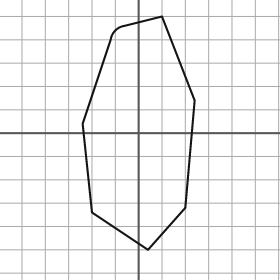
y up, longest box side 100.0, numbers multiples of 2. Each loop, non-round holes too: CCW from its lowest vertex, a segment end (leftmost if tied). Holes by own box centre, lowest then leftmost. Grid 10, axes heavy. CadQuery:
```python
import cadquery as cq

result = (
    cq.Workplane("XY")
    .moveTo(4.0, -50.0)
    .lineTo(20.0, -32.0)
    .lineTo(24.0, 14.0)
    .lineTo(10.0, 50.0)
    .lineTo(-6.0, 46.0)
    .threePointArc((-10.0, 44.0), (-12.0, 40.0))
    .lineTo(-24.0, 4.0)
    .lineTo(-20.0, -34.0)
    .close()
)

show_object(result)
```